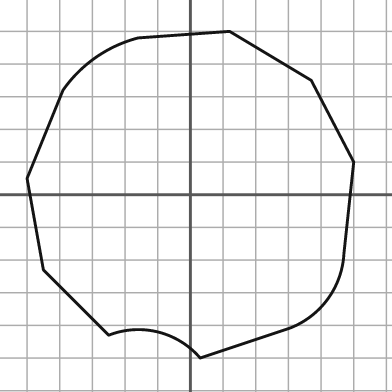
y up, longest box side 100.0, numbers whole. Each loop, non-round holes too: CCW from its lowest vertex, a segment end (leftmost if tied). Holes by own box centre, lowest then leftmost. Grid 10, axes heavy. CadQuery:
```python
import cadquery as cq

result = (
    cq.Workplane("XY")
    .moveTo(3.0, -50.0)
    .lineTo(30.0, -41.0)
    .threePointArc((42.0, -32.0), (47.0, -18.0))
    .lineTo(50.0, 10.0)
    .lineTo(37.0, 35.0)
    .lineTo(12.0, 50.0)
    .lineTo(-16.0, 48.0)
    .threePointArc((-29.0, 42.0), (-39.0, 32.0))
    .lineTo(-50.0, 5.0)
    .lineTo(-45.0, -23.0)
    .lineTo(-25.0, -43.0)
    .threePointArc((-10.0, -42.0), (3.0, -50.0))
    .close()
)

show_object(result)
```